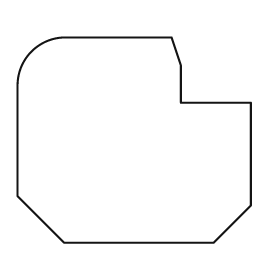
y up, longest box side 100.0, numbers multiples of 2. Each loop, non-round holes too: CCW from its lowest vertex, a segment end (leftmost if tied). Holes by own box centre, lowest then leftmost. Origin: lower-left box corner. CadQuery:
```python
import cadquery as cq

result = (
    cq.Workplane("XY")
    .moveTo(20.0, 0.0)
    .lineTo(84.0, 0.0)
    .lineTo(100.0, 16.0)
    .lineTo(100.0, 60.0)
    .lineTo(70.0, 60.0)
    .lineTo(70.0, 76.0)
    .lineTo(66.0, 88.0)
    .lineTo(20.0, 88.0)
    .threePointArc((6.0, 82.0), (0.0, 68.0))
    .lineTo(0.0, 20.0)
    .close()
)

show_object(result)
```